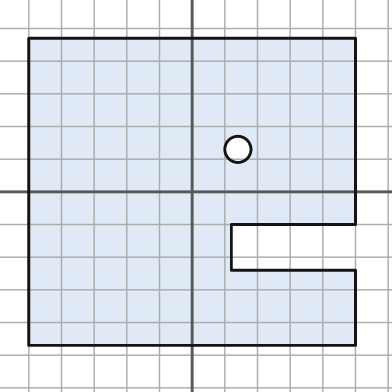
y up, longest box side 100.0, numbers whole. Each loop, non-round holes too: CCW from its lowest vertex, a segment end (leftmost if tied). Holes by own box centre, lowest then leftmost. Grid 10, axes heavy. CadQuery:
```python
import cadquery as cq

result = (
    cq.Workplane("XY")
    .moveTo(-50.0, -47.0)
    .lineTo(50.0, -47.0)
    .lineTo(50.0, -24.0)
    .lineTo(12.0, -24.0)
    .lineTo(12.0, -10.0)
    .lineTo(50.0, -10.0)
    .lineTo(50.0, 47.0)
    .lineTo(-50.0, 47.0)
    .close()
    .moveTo(14.0, 13.0)
    .circle(4.0)
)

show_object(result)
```